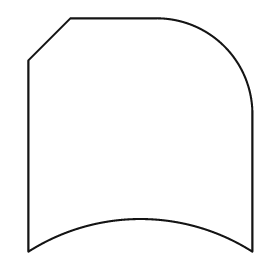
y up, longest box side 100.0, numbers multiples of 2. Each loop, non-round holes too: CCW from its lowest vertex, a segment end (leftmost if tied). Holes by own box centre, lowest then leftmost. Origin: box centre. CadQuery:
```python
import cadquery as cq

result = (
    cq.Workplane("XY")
    .moveTo(-48.0, -50.0)
    .threePointArc((0.0, -36.0), (48.0, -50.0))
    .lineTo(48.0, 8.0)
    .threePointArc((36.0, 38.0), (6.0, 50.0))
    .lineTo(-30.0, 50.0)
    .lineTo(-48.0, 32.0)
    .close()
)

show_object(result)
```